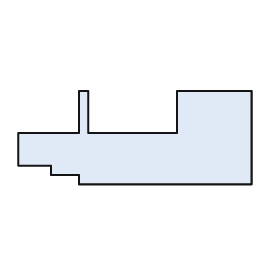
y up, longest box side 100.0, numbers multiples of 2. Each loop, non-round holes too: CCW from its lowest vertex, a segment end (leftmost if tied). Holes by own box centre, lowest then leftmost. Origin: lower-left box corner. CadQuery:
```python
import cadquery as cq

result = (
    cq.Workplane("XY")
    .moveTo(26.0, 0.0)
    .lineTo(100.0, 0.0)
    .lineTo(100.0, 40.0)
    .lineTo(68.0, 40.0)
    .lineTo(68.0, 22.0)
    .lineTo(30.0, 22.0)
    .lineTo(30.0, 40.0)
    .lineTo(26.0, 40.0)
    .lineTo(26.0, 22.0)
    .lineTo(0.0, 22.0)
    .lineTo(0.0, 8.0)
    .lineTo(14.0, 8.0)
    .lineTo(14.0, 4.0)
    .lineTo(26.0, 4.0)
    .close()
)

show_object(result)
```